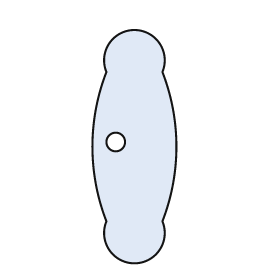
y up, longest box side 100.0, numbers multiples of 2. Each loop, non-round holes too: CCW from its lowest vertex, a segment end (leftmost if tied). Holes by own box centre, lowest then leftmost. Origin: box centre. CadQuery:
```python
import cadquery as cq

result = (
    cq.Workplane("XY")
    .moveTo(-12.0, -32.0)
    .threePointArc((0.0, -50.0), (12.0, -32.0))
    .threePointArc((18.0, 0.0), (12.0, 32.0))
    .threePointArc((0.0, 50.0), (-12.0, 32.0))
    .threePointArc((-18.0, 0.0), (-12.0, -32.0))
    .close()
    .moveTo(-8.0, 2.0)
    .circle(4.0)
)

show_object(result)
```